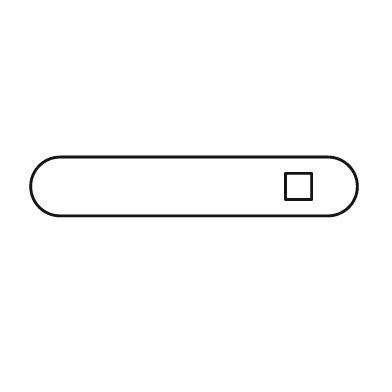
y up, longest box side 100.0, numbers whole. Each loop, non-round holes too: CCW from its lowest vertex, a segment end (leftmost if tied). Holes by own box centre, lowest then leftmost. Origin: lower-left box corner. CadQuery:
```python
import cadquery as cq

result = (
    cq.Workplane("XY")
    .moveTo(9.0, 0.0)
    .lineTo(91.0, 0.0)
    .threePointArc((100.0, 9.0), (91.0, 18.0))
    .lineTo(9.0, 18.0)
    .threePointArc((0.0, 9.0), (9.0, 0.0))
    .close()
    .moveTo(78.0, 5.0)
    .lineTo(86.0, 5.0)
    .lineTo(86.0, 13.0)
    .lineTo(78.0, 13.0)
    .close()
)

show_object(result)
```